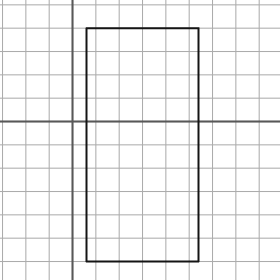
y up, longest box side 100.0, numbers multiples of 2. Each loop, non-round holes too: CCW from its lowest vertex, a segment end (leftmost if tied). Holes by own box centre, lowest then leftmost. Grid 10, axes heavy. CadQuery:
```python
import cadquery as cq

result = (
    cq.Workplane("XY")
    .moveTo(6.0, -60.0)
    .lineTo(54.0, -60.0)
    .lineTo(54.0, 40.0)
    .lineTo(6.0, 40.0)
    .close()
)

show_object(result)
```